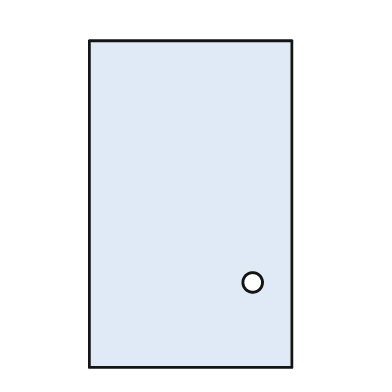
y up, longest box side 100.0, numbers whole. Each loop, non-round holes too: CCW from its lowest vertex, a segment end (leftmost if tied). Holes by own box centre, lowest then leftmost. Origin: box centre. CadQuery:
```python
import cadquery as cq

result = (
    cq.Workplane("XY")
    .moveTo(-31.0, -50.0)
    .lineTo(31.0, -50.0)
    .lineTo(31.0, 50.0)
    .lineTo(-31.0, 50.0)
    .close()
    .moveTo(19.0, -24.0)
    .circle(3.0)
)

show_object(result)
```